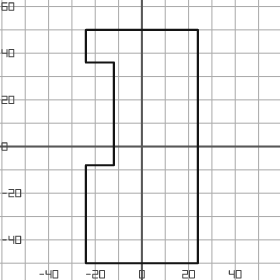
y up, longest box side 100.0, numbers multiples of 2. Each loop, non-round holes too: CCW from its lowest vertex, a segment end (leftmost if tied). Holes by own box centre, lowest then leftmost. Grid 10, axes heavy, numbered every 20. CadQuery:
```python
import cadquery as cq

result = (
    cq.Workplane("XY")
    .moveTo(-24.0, -50.0)
    .lineTo(24.0, -50.0)
    .lineTo(24.0, 50.0)
    .lineTo(-24.0, 50.0)
    .lineTo(-24.0, 36.0)
    .lineTo(-12.0, 36.0)
    .lineTo(-12.0, -8.0)
    .lineTo(-24.0, -8.0)
    .close()
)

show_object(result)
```